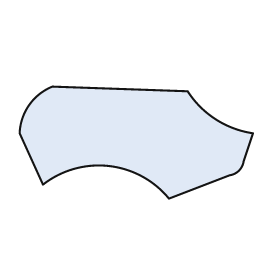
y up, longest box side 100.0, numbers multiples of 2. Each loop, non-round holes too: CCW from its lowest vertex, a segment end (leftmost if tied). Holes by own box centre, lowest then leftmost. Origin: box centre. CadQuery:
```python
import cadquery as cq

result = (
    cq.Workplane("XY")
    .moveTo(14.0, -24.0)
    .lineTo(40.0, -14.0)
    .threePointArc((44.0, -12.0), (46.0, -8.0))
    .lineTo(50.0, 4.0)
    .threePointArc((34.0, 10.0), (22.0, 22.0))
    .lineTo(-36.0, 24.0)
    .threePointArc((-46.0, 16.0), (-50.0, 4.0))
    .lineTo(-40.0, -18.0)
    .threePointArc((-12.0, -10.0), (14.0, -24.0))
    .close()
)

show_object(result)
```